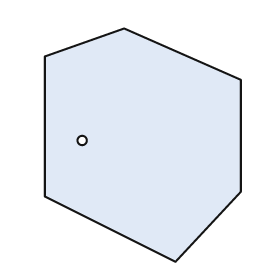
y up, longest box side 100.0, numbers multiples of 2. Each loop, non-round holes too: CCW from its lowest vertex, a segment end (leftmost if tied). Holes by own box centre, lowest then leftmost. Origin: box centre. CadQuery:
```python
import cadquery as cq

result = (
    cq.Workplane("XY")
    .moveTo(14.0, -50.0)
    .lineTo(42.0, -20.0)
    .lineTo(42.0, 28.0)
    .lineTo(-8.0, 50.0)
    .lineTo(-42.0, 38.0)
    .lineTo(-42.0, -22.0)
    .close()
    .moveTo(-26.0, 2.0)
    .circle(2.0)
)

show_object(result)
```